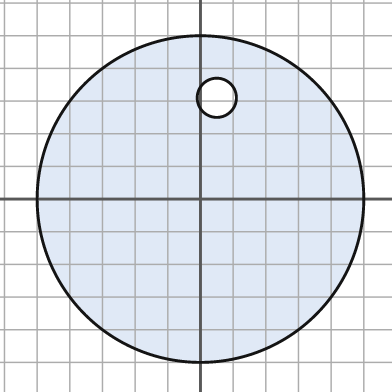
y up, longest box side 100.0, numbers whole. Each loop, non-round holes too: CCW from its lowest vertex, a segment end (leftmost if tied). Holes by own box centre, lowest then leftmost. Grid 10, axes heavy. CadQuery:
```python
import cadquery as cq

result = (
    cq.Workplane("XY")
    .moveTo(0.0, 0.0)
    .circle(50.0)
    .moveTo(5.0, 31.0)
    .circle(6.0)
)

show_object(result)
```